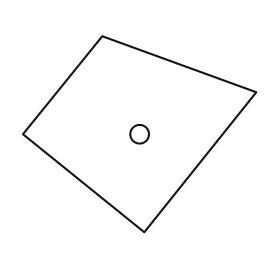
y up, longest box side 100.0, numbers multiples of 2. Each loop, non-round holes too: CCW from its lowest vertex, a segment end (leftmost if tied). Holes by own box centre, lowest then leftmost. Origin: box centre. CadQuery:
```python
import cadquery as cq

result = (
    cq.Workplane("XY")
    .moveTo(2.0, -42.0)
    .lineTo(50.0, 18.0)
    .lineTo(-16.0, 42.0)
    .lineTo(-50.0, 0.0)
    .close()
    .moveTo(0.0, 0.0)
    .circle(4.0)
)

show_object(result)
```